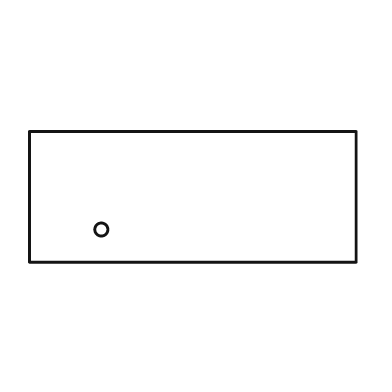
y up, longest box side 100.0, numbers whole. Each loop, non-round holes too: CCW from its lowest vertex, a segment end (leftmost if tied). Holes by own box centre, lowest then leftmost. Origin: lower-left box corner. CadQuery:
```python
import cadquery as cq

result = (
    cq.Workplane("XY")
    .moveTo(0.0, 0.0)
    .lineTo(100.0, 0.0)
    .lineTo(100.0, 40.0)
    .lineTo(0.0, 40.0)
    .close()
    .moveTo(22.0, 10.0)
    .circle(2.0)
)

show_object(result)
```